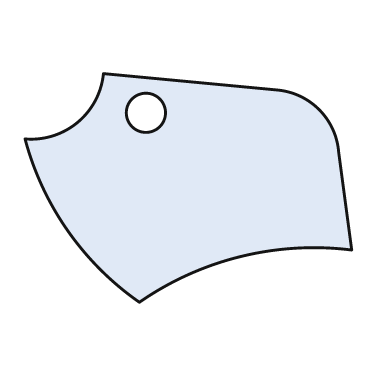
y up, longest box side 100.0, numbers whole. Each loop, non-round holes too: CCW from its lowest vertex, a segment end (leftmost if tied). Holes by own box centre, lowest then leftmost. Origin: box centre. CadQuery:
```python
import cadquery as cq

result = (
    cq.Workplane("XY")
    .moveTo(-15.0, -35.0)
    .threePointArc((16.0, -21.0), (50.0, -19.0))
    .lineTo(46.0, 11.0)
    .threePointArc((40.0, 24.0), (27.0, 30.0))
    .lineTo(-26.0, 35.0)
    .threePointArc((-34.0, 20.0), (-50.0, 15.0))
    .threePointArc((-37.0, -13.0), (-15.0, -35.0))
    .close()
    .moveTo(-13.0, 23.0)
    .circle(6.0)
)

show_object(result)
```